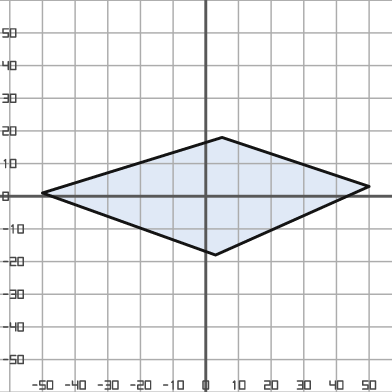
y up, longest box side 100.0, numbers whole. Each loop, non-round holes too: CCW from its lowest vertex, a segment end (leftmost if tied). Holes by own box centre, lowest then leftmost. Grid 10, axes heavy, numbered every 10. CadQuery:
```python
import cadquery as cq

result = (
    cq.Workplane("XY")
    .moveTo(3.0, -18.0)
    .lineTo(50.0, 3.0)
    .lineTo(5.0, 18.0)
    .lineTo(-50.0, 1.0)
    .close()
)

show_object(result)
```